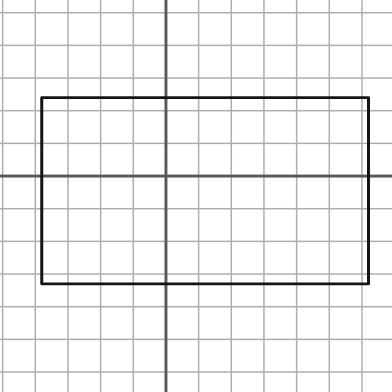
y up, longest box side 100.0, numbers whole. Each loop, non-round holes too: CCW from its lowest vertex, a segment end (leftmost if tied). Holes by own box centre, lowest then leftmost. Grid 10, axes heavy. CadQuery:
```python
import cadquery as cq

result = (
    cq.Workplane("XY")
    .moveTo(-38.0, -33.0)
    .lineTo(62.0, -33.0)
    .lineTo(62.0, 24.0)
    .lineTo(-38.0, 24.0)
    .close()
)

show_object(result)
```